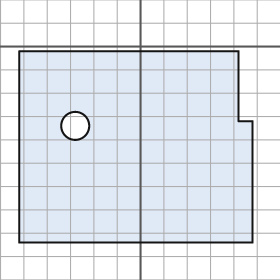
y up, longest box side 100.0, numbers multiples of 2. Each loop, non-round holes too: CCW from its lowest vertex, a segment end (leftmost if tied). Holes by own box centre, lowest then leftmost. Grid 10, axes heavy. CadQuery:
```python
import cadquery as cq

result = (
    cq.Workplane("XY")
    .moveTo(-52.0, -84.0)
    .lineTo(48.0, -84.0)
    .lineTo(48.0, -32.0)
    .lineTo(42.0, -32.0)
    .lineTo(42.0, -2.0)
    .lineTo(-52.0, -2.0)
    .close()
    .moveTo(-28.0, -34.0)
    .circle(6.0)
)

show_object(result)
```